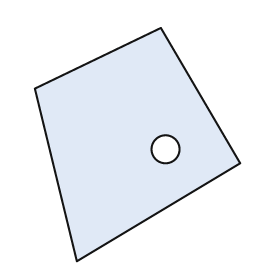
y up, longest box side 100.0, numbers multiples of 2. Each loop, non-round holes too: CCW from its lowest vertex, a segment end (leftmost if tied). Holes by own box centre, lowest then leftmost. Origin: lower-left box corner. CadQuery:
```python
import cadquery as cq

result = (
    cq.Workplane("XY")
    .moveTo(18.0, 0.0)
    .lineTo(88.0, 42.0)
    .lineTo(54.0, 100.0)
    .lineTo(0.0, 74.0)
    .close()
    .moveTo(56.0, 48.0)
    .circle(6.0)
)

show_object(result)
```